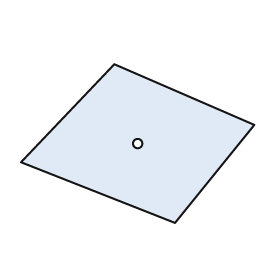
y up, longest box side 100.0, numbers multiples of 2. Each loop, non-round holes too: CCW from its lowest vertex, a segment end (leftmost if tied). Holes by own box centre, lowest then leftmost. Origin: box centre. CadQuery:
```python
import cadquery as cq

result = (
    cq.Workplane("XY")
    .moveTo(16.0, -34.0)
    .lineTo(50.0, 8.0)
    .lineTo(-10.0, 34.0)
    .lineTo(-50.0, -8.0)
    .close()
    .moveTo(0.0, 0.0)
    .circle(2.0)
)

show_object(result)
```